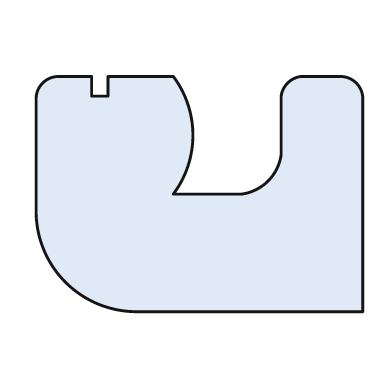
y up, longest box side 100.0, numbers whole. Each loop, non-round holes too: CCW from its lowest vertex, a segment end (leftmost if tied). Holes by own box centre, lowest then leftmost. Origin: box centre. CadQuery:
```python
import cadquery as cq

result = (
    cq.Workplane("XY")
    .moveTo(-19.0, -36.0)
    .lineTo(50.0, -36.0)
    .lineTo(50.0, 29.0)
    .threePointArc((48.0, 34.0), (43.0, 36.0))
    .lineTo(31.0, 36.0)
    .threePointArc((27.0, 34.0), (25.0, 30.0))
    .lineTo(25.0, 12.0)
    .threePointArc((21.0, 4.0), (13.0, 0.0))
    .lineTo(-8.0, 0.0)
    .threePointArc((-2.0, 18.0), (-8.0, 36.0))
    .lineTo(-28.0, 36.0)
    .lineTo(-28.0, 30.0)
    .lineTo(-33.0, 30.0)
    .lineTo(-33.0, 36.0)
    .lineTo(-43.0, 36.0)
    .threePointArc((-48.0, 34.0), (-50.0, 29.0))
    .lineTo(-50.0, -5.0)
    .threePointArc((-41.0, -27.0), (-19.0, -36.0))
    .close()
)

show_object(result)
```